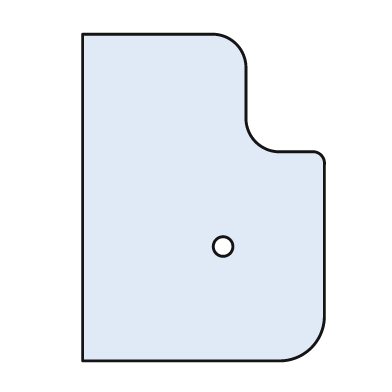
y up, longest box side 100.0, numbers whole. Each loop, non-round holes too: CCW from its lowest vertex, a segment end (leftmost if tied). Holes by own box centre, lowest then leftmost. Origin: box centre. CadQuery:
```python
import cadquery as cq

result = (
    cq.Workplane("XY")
    .moveTo(-37.0, -50.0)
    .lineTo(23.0, -50.0)
    .threePointArc((33.0, -46.0), (37.0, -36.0))
    .lineTo(37.0, 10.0)
    .threePointArc((36.0, 13.0), (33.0, 14.0))
    .lineTo(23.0, 14.0)
    .threePointArc((16.0, 17.0), (13.0, 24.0))
    .lineTo(13.0, 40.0)
    .threePointArc((10.0, 47.0), (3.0, 50.0))
    .lineTo(-37.0, 50.0)
    .close()
    .moveTo(6.0, -15.0)
    .circle(3.0)
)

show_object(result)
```